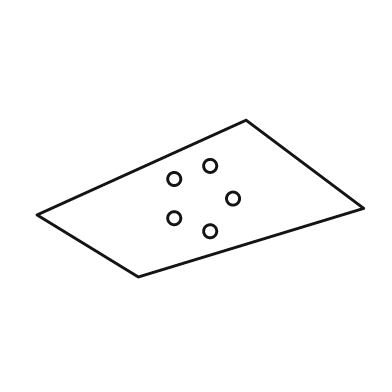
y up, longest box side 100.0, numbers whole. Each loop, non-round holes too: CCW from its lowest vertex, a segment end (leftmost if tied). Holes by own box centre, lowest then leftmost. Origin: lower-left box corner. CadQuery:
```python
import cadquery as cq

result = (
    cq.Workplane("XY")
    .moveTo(31.0, 0.0)
    .lineTo(100.0, 21.0)
    .lineTo(64.0, 48.0)
    .lineTo(0.0, 19.0)
    .close()
    .moveTo(53.0, 14.0)
    .circle(2.0)
    .moveTo(42.0, 18.0)
    .circle(2.0)
    .moveTo(60.0, 24.0)
    .circle(2.0)
    .moveTo(42.0, 30.0)
    .circle(2.0)
    .moveTo(53.0, 34.0)
    .circle(2.0)
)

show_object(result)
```